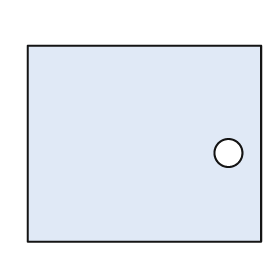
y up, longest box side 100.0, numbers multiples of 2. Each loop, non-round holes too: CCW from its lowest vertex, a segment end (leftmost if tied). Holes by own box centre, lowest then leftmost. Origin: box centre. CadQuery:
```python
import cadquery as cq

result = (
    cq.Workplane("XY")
    .moveTo(-50.0, -42.0)
    .lineTo(50.0, -42.0)
    .lineTo(50.0, 42.0)
    .lineTo(-50.0, 42.0)
    .close()
    .moveTo(36.0, -4.0)
    .circle(6.0)
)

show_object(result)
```